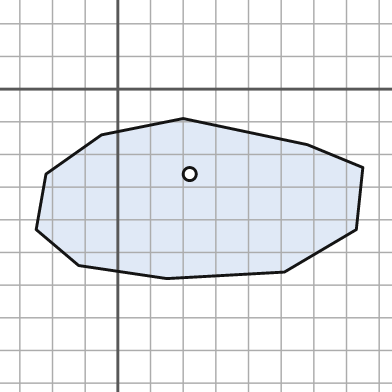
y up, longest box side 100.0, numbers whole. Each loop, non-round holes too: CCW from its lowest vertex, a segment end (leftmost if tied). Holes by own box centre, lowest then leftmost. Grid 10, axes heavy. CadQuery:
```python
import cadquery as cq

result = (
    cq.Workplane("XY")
    .moveTo(15.0, -58.0)
    .lineTo(51.0, -56.0)
    .lineTo(73.0, -43.0)
    .lineTo(75.0, -24.0)
    .lineTo(58.0, -17.0)
    .lineTo(20.0, -9.0)
    .lineTo(-5.0, -14.0)
    .lineTo(-22.0, -26.0)
    .lineTo(-25.0, -43.0)
    .lineTo(-12.0, -54.0)
    .close()
    .moveTo(22.0, -26.0)
    .circle(2.0)
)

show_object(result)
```